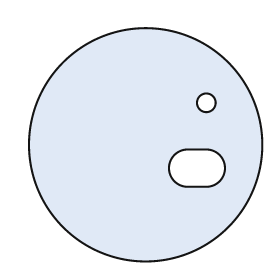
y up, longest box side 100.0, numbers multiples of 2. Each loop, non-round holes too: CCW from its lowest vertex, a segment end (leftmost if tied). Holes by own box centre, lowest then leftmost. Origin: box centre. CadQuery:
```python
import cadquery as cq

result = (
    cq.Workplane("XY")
    .moveTo(0.0, 0.0)
    .circle(50.0)
    .moveTo(18.0, -18.0)
    .lineTo(26.0, -18.0)
    .threePointArc((34.0, -10.0), (26.0, -2.0))
    .lineTo(18.0, -2.0)
    .threePointArc((10.0, -10.0), (18.0, -18.0))
    .close()
    .moveTo(26.0, 18.0)
    .circle(4.0)
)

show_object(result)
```